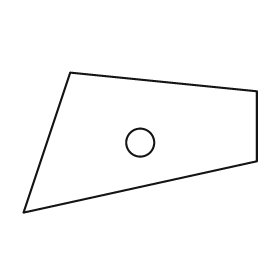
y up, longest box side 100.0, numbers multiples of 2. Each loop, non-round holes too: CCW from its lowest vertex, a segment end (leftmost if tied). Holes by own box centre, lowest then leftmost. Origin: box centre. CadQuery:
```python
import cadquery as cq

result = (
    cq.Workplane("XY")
    .moveTo(-50.0, -30.0)
    .lineTo(50.0, -8.0)
    .lineTo(50.0, 22.0)
    .lineTo(-30.0, 30.0)
    .close()
    .moveTo(0.0, 0.0)
    .circle(6.0)
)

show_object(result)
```